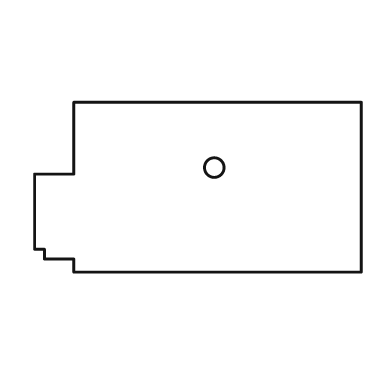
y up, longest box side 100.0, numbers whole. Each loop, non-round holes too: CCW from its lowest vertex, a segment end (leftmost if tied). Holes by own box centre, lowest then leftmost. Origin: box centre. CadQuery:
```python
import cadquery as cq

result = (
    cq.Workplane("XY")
    .moveTo(-38.0, -26.0)
    .lineTo(50.0, -26.0)
    .lineTo(50.0, 26.0)
    .lineTo(-38.0, 26.0)
    .lineTo(-38.0, 4.0)
    .lineTo(-50.0, 4.0)
    .lineTo(-50.0, -19.0)
    .lineTo(-47.0, -19.0)
    .lineTo(-47.0, -22.0)
    .lineTo(-38.0, -22.0)
    .close()
    .moveTo(5.0, 6.0)
    .circle(3.0)
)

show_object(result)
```